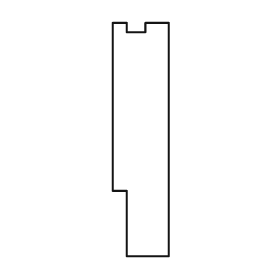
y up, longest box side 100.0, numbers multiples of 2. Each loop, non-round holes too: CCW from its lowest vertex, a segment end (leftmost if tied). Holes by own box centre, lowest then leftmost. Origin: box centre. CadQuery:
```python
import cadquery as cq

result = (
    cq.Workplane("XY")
    .moveTo(-6.0, -50.0)
    .lineTo(12.0, -50.0)
    .lineTo(12.0, 50.0)
    .lineTo(2.0, 50.0)
    .lineTo(2.0, 46.0)
    .lineTo(-6.0, 46.0)
    .lineTo(-6.0, 50.0)
    .lineTo(-12.0, 50.0)
    .lineTo(-12.0, -22.0)
    .lineTo(-6.0, -22.0)
    .close()
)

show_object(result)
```